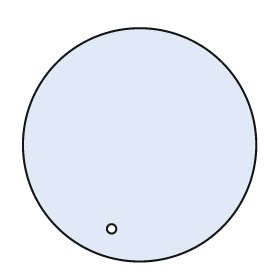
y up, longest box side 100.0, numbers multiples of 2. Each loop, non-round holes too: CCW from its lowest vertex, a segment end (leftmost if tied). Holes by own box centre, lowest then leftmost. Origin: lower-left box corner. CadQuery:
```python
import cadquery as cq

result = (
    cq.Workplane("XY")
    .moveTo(50.0, 50.0)
    .circle(50.0)
    .moveTo(38.0, 14.0)
    .circle(2.0)
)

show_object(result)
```